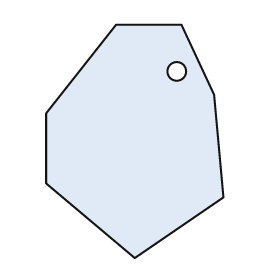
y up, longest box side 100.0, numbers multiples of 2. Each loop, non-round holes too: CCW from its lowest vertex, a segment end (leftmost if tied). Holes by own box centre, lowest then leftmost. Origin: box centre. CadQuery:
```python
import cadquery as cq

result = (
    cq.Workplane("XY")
    .moveTo(0.0, -50.0)
    .lineTo(38.0, -24.0)
    .lineTo(34.0, 20.0)
    .lineTo(20.0, 50.0)
    .lineTo(-8.0, 50.0)
    .lineTo(-38.0, 12.0)
    .lineTo(-38.0, -18.0)
    .close()
    .moveTo(18.0, 30.0)
    .circle(4.0)
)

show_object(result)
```